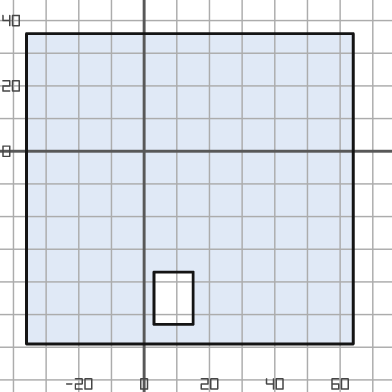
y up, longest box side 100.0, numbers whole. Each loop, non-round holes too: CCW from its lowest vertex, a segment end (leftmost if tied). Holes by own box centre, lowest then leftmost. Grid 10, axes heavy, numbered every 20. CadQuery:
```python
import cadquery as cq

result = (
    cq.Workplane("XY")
    .moveTo(-36.0, -59.0)
    .lineTo(64.0, -59.0)
    .lineTo(64.0, 36.0)
    .lineTo(-36.0, 36.0)
    .close()
    .moveTo(3.0, -53.0)
    .lineTo(15.0, -53.0)
    .lineTo(15.0, -37.0)
    .lineTo(3.0, -37.0)
    .close()
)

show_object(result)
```